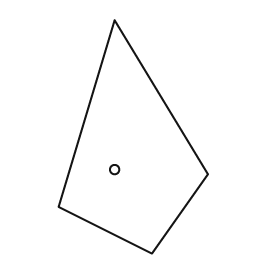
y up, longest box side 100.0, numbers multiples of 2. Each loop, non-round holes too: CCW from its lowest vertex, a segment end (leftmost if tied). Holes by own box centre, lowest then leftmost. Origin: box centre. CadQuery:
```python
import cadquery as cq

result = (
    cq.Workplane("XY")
    .moveTo(8.0, -50.0)
    .lineTo(32.0, -16.0)
    .lineTo(-8.0, 50.0)
    .lineTo(-32.0, -30.0)
    .close()
    .moveTo(-8.0, -14.0)
    .circle(2.0)
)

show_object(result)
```